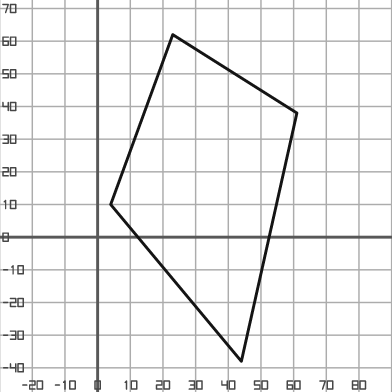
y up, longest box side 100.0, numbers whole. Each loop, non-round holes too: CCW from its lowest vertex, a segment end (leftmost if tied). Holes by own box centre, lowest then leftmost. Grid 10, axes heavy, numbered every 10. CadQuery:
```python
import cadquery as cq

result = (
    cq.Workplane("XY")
    .moveTo(44.0, -38.0)
    .lineTo(61.0, 38.0)
    .lineTo(23.0, 62.0)
    .lineTo(4.0, 10.0)
    .close()
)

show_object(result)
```